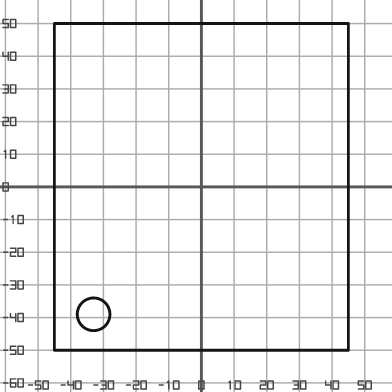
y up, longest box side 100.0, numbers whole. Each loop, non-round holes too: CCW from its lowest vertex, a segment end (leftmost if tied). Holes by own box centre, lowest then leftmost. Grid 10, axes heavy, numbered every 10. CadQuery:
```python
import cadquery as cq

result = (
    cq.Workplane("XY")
    .moveTo(-45.0, -50.0)
    .lineTo(45.0, -50.0)
    .lineTo(45.0, 50.0)
    .lineTo(-45.0, 50.0)
    .close()
    .moveTo(-33.0, -39.0)
    .circle(5.0)
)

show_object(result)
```